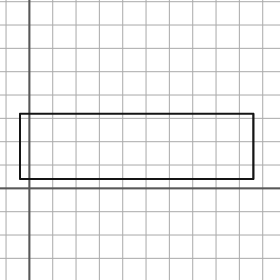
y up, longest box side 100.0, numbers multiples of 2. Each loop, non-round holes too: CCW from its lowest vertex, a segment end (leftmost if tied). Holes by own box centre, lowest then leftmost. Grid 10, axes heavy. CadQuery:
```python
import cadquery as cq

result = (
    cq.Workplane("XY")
    .moveTo(-4.0, 4.0)
    .lineTo(96.0, 4.0)
    .lineTo(96.0, 32.0)
    .lineTo(-4.0, 32.0)
    .close()
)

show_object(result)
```